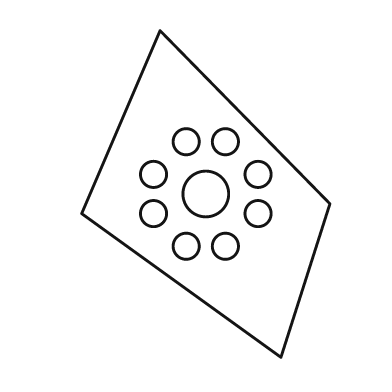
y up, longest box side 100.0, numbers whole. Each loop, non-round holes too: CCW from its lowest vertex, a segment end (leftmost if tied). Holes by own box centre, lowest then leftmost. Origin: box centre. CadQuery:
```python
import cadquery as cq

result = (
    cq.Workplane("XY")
    .moveTo(23.0, -50.0)
    .lineTo(38.0, -3.0)
    .lineTo(-14.0, 50.0)
    .lineTo(-38.0, -6.0)
    .close()
    .moveTo(-6.0, -16.0)
    .circle(4.0)
    .moveTo(6.0, -16.0)
    .circle(4.0)
    .moveTo(-16.0, -6.0)
    .circle(4.0)
    .moveTo(16.0, -6.0)
    .circle(4.0)
    .moveTo(0.0, 0.0)
    .circle(7.0)
    .moveTo(-16.0, 6.0)
    .circle(4.0)
    .moveTo(16.0, 6.0)
    .circle(4.0)
    .moveTo(-6.0, 16.0)
    .circle(4.0)
    .moveTo(6.0, 16.0)
    .circle(4.0)
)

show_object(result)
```